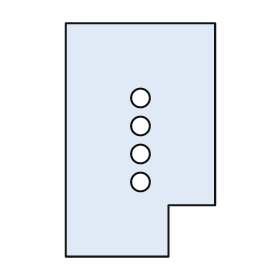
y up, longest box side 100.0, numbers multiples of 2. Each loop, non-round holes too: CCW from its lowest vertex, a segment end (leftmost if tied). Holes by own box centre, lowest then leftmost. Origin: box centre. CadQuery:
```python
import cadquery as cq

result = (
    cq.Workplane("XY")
    .moveTo(-32.0, -50.0)
    .lineTo(12.0, -50.0)
    .lineTo(12.0, -28.0)
    .lineTo(32.0, -28.0)
    .lineTo(32.0, 50.0)
    .lineTo(-32.0, 50.0)
    .close()
    .moveTo(0.0, -18.0)
    .circle(4.0)
    .moveTo(0.0, -6.0)
    .circle(4.0)
    .moveTo(0.0, 6.0)
    .circle(4.0)
    .moveTo(0.0, 18.0)
    .circle(4.0)
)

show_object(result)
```